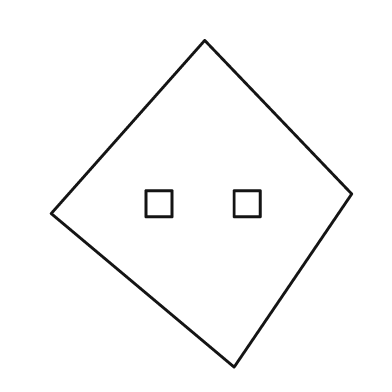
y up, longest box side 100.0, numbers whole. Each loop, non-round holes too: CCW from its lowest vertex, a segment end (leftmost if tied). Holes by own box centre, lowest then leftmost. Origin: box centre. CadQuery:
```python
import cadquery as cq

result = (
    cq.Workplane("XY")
    .moveTo(10.0, -50.0)
    .lineTo(46.0, 3.0)
    .lineTo(1.0, 50.0)
    .lineTo(-46.0, -3.0)
    .close()
    .moveTo(-17.0, -4.0)
    .lineTo(-9.0, -4.0)
    .lineTo(-9.0, 4.0)
    .lineTo(-17.0, 4.0)
    .close()
    .moveTo(10.0, -4.0)
    .lineTo(18.0, -4.0)
    .lineTo(18.0, 4.0)
    .lineTo(10.0, 4.0)
    .close()
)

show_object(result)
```